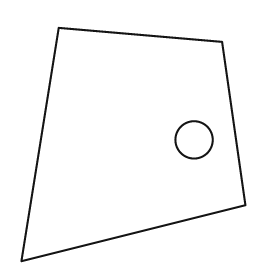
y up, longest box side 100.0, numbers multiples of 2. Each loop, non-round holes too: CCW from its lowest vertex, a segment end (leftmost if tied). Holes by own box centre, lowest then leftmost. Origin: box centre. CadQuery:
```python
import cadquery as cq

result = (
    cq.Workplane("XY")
    .moveTo(-48.0, -50.0)
    .lineTo(48.0, -26.0)
    .lineTo(38.0, 44.0)
    .lineTo(-32.0, 50.0)
    .close()
    .moveTo(26.0, 2.0)
    .circle(8.0)
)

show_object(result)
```